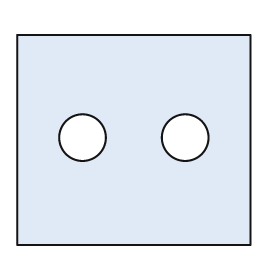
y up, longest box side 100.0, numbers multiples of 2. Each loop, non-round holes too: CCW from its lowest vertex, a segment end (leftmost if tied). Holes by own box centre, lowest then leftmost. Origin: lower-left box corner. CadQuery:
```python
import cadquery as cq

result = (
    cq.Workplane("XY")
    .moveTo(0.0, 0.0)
    .lineTo(100.0, 0.0)
    .lineTo(100.0, 90.0)
    .lineTo(0.0, 90.0)
    .close()
    .moveTo(28.0, 46.0)
    .circle(10.0)
    .moveTo(72.0, 46.0)
    .circle(10.0)
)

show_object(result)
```